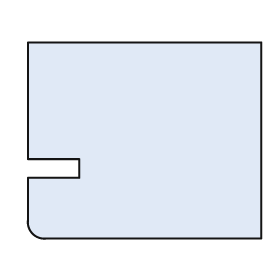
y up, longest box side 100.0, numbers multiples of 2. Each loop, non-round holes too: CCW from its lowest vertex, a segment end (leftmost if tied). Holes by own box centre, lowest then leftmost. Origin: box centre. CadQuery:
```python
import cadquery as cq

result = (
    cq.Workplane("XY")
    .moveTo(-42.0, -42.0)
    .lineTo(50.0, -42.0)
    .lineTo(50.0, 42.0)
    .lineTo(-50.0, 42.0)
    .lineTo(-50.0, -8.0)
    .lineTo(-28.0, -8.0)
    .lineTo(-28.0, -16.0)
    .lineTo(-50.0, -16.0)
    .lineTo(-50.0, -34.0)
    .threePointArc((-48.0, -40.0), (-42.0, -42.0))
    .close()
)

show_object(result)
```